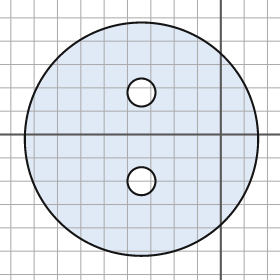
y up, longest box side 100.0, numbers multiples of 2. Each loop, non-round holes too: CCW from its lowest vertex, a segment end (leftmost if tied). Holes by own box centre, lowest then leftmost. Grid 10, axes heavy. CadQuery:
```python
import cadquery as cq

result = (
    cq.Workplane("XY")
    .moveTo(-34.0, -2.0)
    .circle(50.0)
    .moveTo(-34.0, -20.0)
    .circle(6.0)
    .moveTo(-34.0, 18.0)
    .circle(6.0)
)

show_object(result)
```